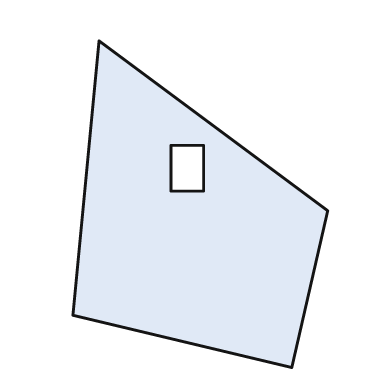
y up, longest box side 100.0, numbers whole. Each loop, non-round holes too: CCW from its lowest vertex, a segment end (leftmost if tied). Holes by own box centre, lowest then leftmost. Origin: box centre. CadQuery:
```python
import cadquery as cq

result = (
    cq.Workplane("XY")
    .moveTo(28.0, -50.0)
    .lineTo(39.0, -2.0)
    .lineTo(-31.0, 50.0)
    .lineTo(-39.0, -34.0)
    .close()
    .moveTo(-9.0, 4.0)
    .lineTo(1.0, 4.0)
    .lineTo(1.0, 18.0)
    .lineTo(-9.0, 18.0)
    .close()
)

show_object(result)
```